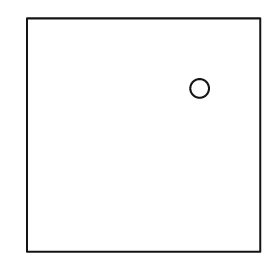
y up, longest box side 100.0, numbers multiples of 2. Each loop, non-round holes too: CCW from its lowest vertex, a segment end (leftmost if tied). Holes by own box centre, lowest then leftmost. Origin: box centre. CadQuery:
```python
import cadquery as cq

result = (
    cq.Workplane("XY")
    .moveTo(-50.0, -50.0)
    .lineTo(50.0, -50.0)
    .lineTo(50.0, 50.0)
    .lineTo(-50.0, 50.0)
    .close()
    .moveTo(24.0, 20.0)
    .circle(4.0)
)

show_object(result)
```